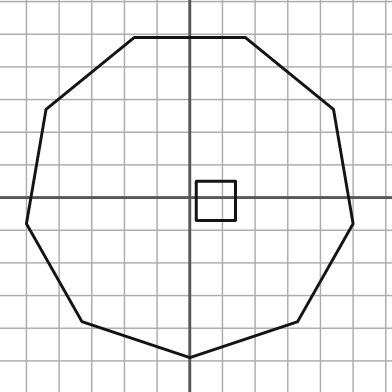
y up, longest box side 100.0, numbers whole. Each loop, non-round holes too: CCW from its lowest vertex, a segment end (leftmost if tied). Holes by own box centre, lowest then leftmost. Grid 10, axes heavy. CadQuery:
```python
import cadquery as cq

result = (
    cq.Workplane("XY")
    .moveTo(0.0, -49.0)
    .lineTo(33.0, -38.0)
    .lineTo(50.0, -8.0)
    .lineTo(44.0, 27.0)
    .lineTo(17.0, 49.0)
    .lineTo(-17.0, 49.0)
    .lineTo(-44.0, 27.0)
    .lineTo(-50.0, -8.0)
    .lineTo(-33.0, -38.0)
    .close()
    .moveTo(2.0, -7.0)
    .lineTo(14.0, -7.0)
    .lineTo(14.0, 5.0)
    .lineTo(2.0, 5.0)
    .close()
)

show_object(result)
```